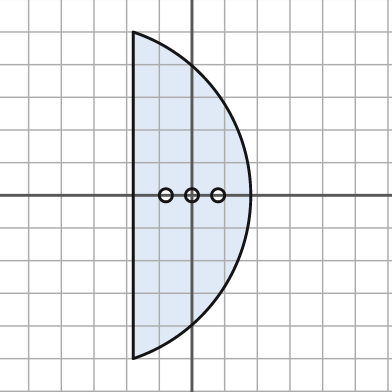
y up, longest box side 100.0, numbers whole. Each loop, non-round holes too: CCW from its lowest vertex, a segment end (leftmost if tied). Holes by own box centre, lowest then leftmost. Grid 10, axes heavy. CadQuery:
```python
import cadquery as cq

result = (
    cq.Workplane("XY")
    .moveTo(-18.0, -50.0)
    .threePointArc((18.0, 0.0), (-18.0, 50.0))
    .close()
    .moveTo(-8.0, 0.0)
    .circle(2.0)
    .moveTo(0.0, 0.0)
    .circle(2.0)
    .moveTo(8.0, 0.0)
    .circle(2.0)
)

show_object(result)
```